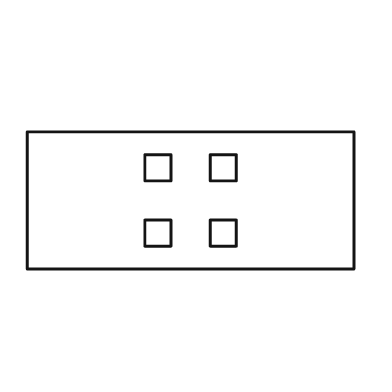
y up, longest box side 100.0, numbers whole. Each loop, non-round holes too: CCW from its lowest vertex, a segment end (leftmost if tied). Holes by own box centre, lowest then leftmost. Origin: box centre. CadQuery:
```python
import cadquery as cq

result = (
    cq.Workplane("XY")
    .moveTo(-50.0, -21.0)
    .lineTo(50.0, -21.0)
    .lineTo(50.0, 21.0)
    .lineTo(-50.0, 21.0)
    .close()
    .moveTo(-14.0, -14.0)
    .lineTo(-6.0, -14.0)
    .lineTo(-6.0, -6.0)
    .lineTo(-14.0, -6.0)
    .close()
    .moveTo(6.0, -14.0)
    .lineTo(14.0, -14.0)
    .lineTo(14.0, -6.0)
    .lineTo(6.0, -6.0)
    .close()
    .moveTo(-14.0, 6.0)
    .lineTo(-6.0, 6.0)
    .lineTo(-6.0, 14.0)
    .lineTo(-14.0, 14.0)
    .close()
    .moveTo(6.0, 6.0)
    .lineTo(14.0, 6.0)
    .lineTo(14.0, 14.0)
    .lineTo(6.0, 14.0)
    .close()
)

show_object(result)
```